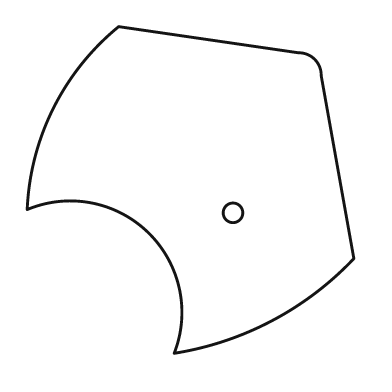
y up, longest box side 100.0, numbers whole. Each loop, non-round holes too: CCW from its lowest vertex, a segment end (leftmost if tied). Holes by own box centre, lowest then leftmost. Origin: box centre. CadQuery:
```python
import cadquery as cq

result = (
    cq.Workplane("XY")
    .moveTo(-5.0, -50.0)
    .threePointArc((25.0, -40.0), (50.0, -21.0))
    .lineTo(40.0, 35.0)
    .threePointArc((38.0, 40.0), (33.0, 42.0))
    .lineTo(-22.0, 50.0)
    .threePointArc((-42.0, 25.0), (-50.0, -6.0))
    .threePointArc((-13.0, -13.0), (-5.0, -50.0))
    .close()
    .moveTo(13.0, -7.0)
    .circle(3.0)
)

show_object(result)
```